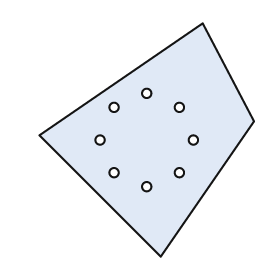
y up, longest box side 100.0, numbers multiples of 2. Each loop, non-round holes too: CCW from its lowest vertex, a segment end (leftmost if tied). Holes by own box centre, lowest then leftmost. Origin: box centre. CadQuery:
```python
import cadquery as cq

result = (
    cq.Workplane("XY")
    .moveTo(6.0, -50.0)
    .lineTo(46.0, 8.0)
    .lineTo(24.0, 50.0)
    .lineTo(-46.0, 2.0)
    .close()
    .moveTo(0.0, -20.0)
    .circle(2.0)
    .moveTo(-14.0, -14.0)
    .circle(2.0)
    .moveTo(14.0, -14.0)
    .circle(2.0)
    .moveTo(-20.0, 0.0)
    .circle(2.0)
    .moveTo(20.0, 0.0)
    .circle(2.0)
    .moveTo(-14.0, 14.0)
    .circle(2.0)
    .moveTo(14.0, 14.0)
    .circle(2.0)
    .moveTo(0.0, 20.0)
    .circle(2.0)
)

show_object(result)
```